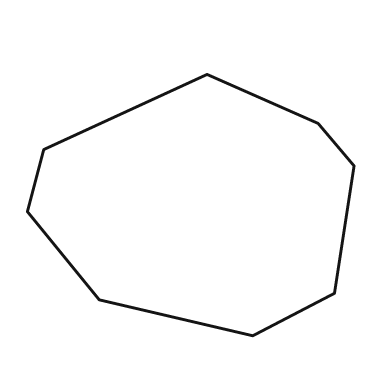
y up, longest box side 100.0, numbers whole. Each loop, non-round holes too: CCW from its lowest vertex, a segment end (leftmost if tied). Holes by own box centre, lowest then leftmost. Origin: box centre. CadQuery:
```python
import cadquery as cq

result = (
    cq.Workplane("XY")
    .moveTo(19.0, -40.0)
    .lineTo(44.0, -27.0)
    .lineTo(50.0, 12.0)
    .lineTo(39.0, 25.0)
    .lineTo(5.0, 40.0)
    .lineTo(-45.0, 17.0)
    .lineTo(-50.0, -2.0)
    .lineTo(-28.0, -29.0)
    .close()
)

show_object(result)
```